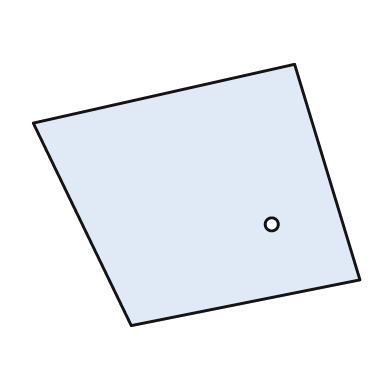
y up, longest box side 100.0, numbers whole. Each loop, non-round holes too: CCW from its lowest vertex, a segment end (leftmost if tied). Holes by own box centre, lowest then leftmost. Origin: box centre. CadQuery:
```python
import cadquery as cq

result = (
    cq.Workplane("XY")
    .moveTo(-20.0, -40.0)
    .lineTo(50.0, -26.0)
    .lineTo(30.0, 40.0)
    .lineTo(-50.0, 22.0)
    .close()
    .moveTo(23.0, -9.0)
    .circle(2.0)
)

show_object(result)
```